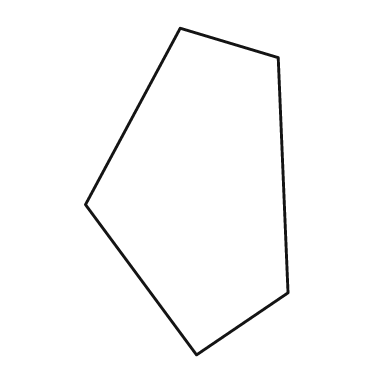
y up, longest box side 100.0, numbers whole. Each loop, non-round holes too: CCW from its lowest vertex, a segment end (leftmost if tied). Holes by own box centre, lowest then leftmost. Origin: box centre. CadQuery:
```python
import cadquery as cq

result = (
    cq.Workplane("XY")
    .moveTo(3.0, -50.0)
    .lineTo(31.0, -31.0)
    .lineTo(28.0, 41.0)
    .lineTo(-2.0, 50.0)
    .lineTo(-31.0, -4.0)
    .close()
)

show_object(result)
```